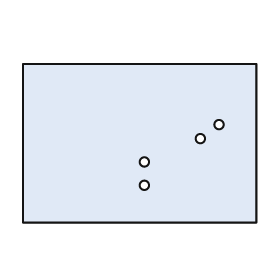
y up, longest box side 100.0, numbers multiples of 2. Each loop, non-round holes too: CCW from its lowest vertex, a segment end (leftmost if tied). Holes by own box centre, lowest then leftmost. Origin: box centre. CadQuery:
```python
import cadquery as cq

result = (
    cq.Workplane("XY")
    .moveTo(-50.0, -34.0)
    .lineTo(50.0, -34.0)
    .lineTo(50.0, 34.0)
    .lineTo(-50.0, 34.0)
    .close()
    .moveTo(2.0, -18.0)
    .circle(2.0)
    .moveTo(2.0, -8.0)
    .circle(2.0)
    .moveTo(26.0, 2.0)
    .circle(2.0)
    .moveTo(34.0, 8.0)
    .circle(2.0)
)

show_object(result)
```